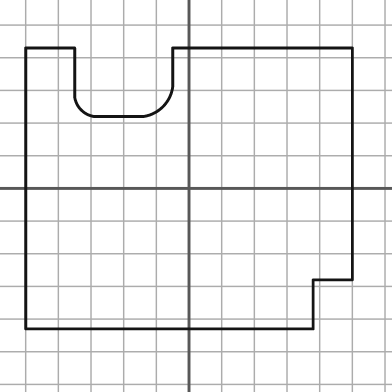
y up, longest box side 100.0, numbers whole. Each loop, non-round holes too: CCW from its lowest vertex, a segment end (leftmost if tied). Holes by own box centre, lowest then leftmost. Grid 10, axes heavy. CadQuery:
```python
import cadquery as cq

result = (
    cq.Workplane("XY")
    .moveTo(-50.0, -43.0)
    .lineTo(38.0, -43.0)
    .lineTo(38.0, -28.0)
    .lineTo(50.0, -28.0)
    .lineTo(50.0, 43.0)
    .lineTo(-5.0, 43.0)
    .lineTo(-5.0, 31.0)
    .threePointArc((-8.0, 25.0), (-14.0, 22.0))
    .lineTo(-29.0, 22.0)
    .threePointArc((-33.0, 24.0), (-35.0, 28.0))
    .lineTo(-35.0, 43.0)
    .lineTo(-50.0, 43.0)
    .close()
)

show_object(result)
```